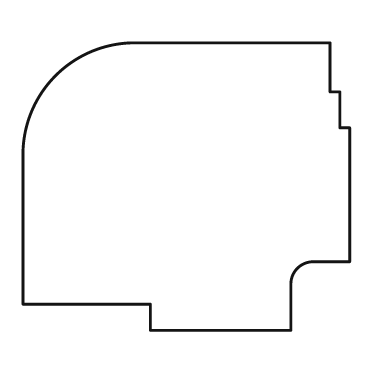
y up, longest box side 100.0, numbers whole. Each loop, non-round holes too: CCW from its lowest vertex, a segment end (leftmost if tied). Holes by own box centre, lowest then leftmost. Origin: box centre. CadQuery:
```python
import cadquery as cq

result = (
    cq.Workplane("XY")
    .moveTo(-11.0, -44.0)
    .lineTo(32.0, -44.0)
    .lineTo(32.0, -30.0)
    .threePointArc((34.0, -25.0), (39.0, -23.0))
    .lineTo(50.0, -23.0)
    .lineTo(50.0, 18.0)
    .lineTo(47.0, 18.0)
    .lineTo(47.0, 29.0)
    .lineTo(44.0, 29.0)
    .lineTo(44.0, 44.0)
    .lineTo(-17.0, 44.0)
    .threePointArc((-40.0, 34.0), (-50.0, 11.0))
    .lineTo(-50.0, -36.0)
    .lineTo(-11.0, -36.0)
    .close()
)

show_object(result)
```